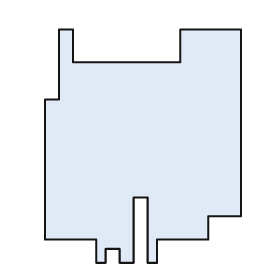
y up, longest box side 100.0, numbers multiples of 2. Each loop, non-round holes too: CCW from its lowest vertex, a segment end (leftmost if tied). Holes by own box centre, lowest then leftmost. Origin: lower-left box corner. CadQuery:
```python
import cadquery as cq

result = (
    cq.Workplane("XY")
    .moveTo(22.0, 0.0)
    .lineTo(26.0, 0.0)
    .lineTo(26.0, 6.0)
    .lineTo(32.0, 6.0)
    .lineTo(32.0, 0.0)
    .lineTo(38.0, 0.0)
    .lineTo(38.0, 28.0)
    .lineTo(44.0, 28.0)
    .lineTo(44.0, 0.0)
    .lineTo(48.0, 0.0)
    .lineTo(48.0, 10.0)
    .lineTo(70.0, 10.0)
    .lineTo(70.0, 20.0)
    .lineTo(84.0, 20.0)
    .lineTo(84.0, 100.0)
    .lineTo(58.0, 100.0)
    .lineTo(58.0, 86.0)
    .lineTo(12.0, 86.0)
    .lineTo(12.0, 100.0)
    .lineTo(6.0, 100.0)
    .lineTo(6.0, 70.0)
    .lineTo(0.0, 70.0)
    .lineTo(0.0, 10.0)
    .lineTo(22.0, 10.0)
    .close()
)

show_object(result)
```